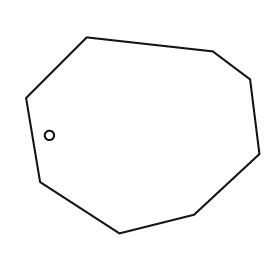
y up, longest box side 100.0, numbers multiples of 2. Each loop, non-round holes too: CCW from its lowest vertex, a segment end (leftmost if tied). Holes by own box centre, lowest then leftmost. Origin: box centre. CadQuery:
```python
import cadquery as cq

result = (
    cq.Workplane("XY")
    .moveTo(-10.0, -42.0)
    .lineTo(22.0, -34.0)
    .lineTo(50.0, -8.0)
    .lineTo(46.0, 24.0)
    .lineTo(30.0, 36.0)
    .lineTo(-24.0, 42.0)
    .lineTo(-50.0, 16.0)
    .lineTo(-44.0, -20.0)
    .close()
    .moveTo(-40.0, 0.0)
    .circle(2.0)
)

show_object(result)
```